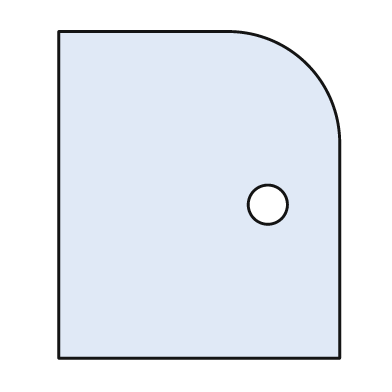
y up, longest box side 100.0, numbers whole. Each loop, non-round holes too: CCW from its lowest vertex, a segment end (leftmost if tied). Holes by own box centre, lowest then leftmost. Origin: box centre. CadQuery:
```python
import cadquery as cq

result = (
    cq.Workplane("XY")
    .moveTo(-43.0, -50.0)
    .lineTo(43.0, -50.0)
    .lineTo(43.0, 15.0)
    .threePointArc((33.0, 40.0), (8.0, 50.0))
    .lineTo(-43.0, 50.0)
    .close()
    .moveTo(21.0, -3.0)
    .circle(6.0)
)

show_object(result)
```